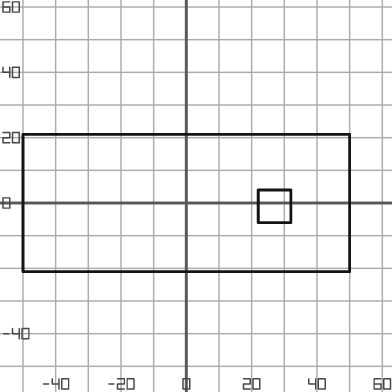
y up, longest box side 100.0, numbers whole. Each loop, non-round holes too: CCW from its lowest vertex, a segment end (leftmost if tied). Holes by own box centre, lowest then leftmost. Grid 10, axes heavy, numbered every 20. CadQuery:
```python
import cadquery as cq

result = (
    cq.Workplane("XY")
    .moveTo(-50.0, -21.0)
    .lineTo(50.0, -21.0)
    .lineTo(50.0, 21.0)
    .lineTo(-50.0, 21.0)
    .close()
    .moveTo(22.0, -6.0)
    .lineTo(32.0, -6.0)
    .lineTo(32.0, 4.0)
    .lineTo(22.0, 4.0)
    .close()
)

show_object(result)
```